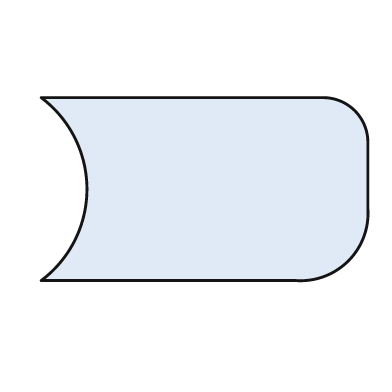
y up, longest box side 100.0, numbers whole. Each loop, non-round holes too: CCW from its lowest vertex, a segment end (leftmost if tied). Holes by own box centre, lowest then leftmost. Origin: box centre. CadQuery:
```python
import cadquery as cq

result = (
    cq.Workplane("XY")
    .moveTo(-50.0, -28.0)
    .lineTo(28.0, -28.0)
    .threePointArc((44.0, -22.0), (50.0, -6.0))
    .lineTo(50.0, 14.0)
    .threePointArc((46.0, 24.0), (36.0, 28.0))
    .lineTo(-50.0, 28.0)
    .threePointArc((-36.0, 0.0), (-50.0, -28.0))
    .close()
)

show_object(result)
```